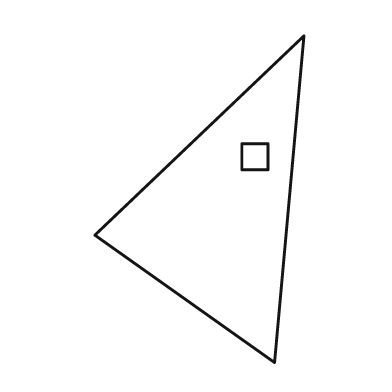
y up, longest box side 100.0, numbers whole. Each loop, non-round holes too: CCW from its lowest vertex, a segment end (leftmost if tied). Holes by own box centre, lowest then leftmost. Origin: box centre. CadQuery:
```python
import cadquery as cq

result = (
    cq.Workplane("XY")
    .moveTo(23.0, -50.0)
    .lineTo(32.0, 50.0)
    .lineTo(-32.0, -11.0)
    .close()
    .moveTo(13.0, 9.0)
    .lineTo(21.0, 9.0)
    .lineTo(21.0, 17.0)
    .lineTo(13.0, 17.0)
    .close()
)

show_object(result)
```